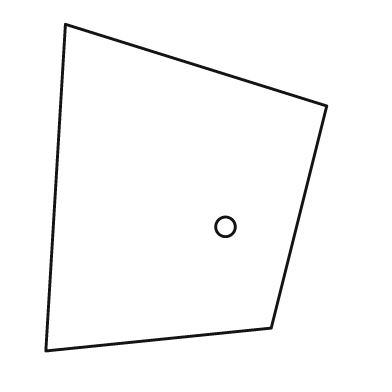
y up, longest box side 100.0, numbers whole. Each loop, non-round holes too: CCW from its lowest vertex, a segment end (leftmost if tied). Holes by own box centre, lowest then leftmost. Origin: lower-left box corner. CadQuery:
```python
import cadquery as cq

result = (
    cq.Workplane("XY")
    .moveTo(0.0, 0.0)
    .lineTo(69.0, 7.0)
    .lineTo(86.0, 75.0)
    .lineTo(6.0, 100.0)
    .close()
    .moveTo(55.0, 38.0)
    .circle(3.0)
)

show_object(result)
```